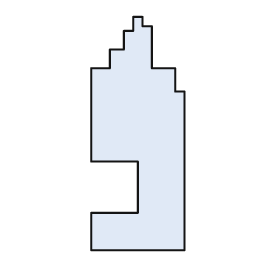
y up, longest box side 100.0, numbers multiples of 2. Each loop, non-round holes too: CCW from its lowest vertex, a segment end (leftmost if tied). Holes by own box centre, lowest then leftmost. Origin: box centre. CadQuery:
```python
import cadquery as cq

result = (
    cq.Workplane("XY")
    .moveTo(-20.0, -50.0)
    .lineTo(20.0, -50.0)
    .lineTo(20.0, 18.0)
    .lineTo(16.0, 18.0)
    .lineTo(16.0, 28.0)
    .lineTo(6.0, 28.0)
    .lineTo(6.0, 46.0)
    .lineTo(2.0, 46.0)
    .lineTo(2.0, 50.0)
    .lineTo(-2.0, 50.0)
    .lineTo(-2.0, 44.0)
    .lineTo(-6.0, 44.0)
    .lineTo(-6.0, 36.0)
    .lineTo(-12.0, 36.0)
    .lineTo(-12.0, 28.0)
    .lineTo(-20.0, 28.0)
    .lineTo(-20.0, -12.0)
    .lineTo(0.0, -12.0)
    .lineTo(0.0, -34.0)
    .lineTo(-20.0, -34.0)
    .close()
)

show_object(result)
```